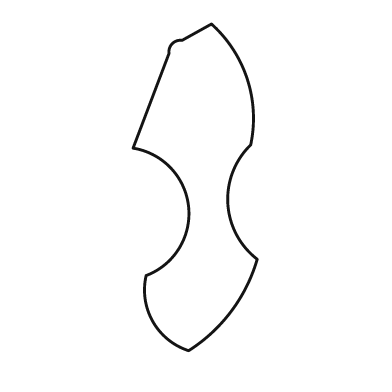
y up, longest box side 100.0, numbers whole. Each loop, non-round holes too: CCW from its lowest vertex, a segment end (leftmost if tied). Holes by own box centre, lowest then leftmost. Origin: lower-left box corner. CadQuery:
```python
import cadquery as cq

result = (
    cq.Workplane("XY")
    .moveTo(17.0, 0.0)
    .threePointArc((30.0, 12.0), (38.0, 28.0))
    .threePointArc((29.0, 45.0), (36.0, 63.0))
    .threePointArc((35.0, 83.0), (24.0, 100.0))
    .lineTo(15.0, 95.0)
    .threePointArc((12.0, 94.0), (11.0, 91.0))
    .lineTo(0.0, 62.0)
    .threePointArc((17.0, 44.0), (4.0, 23.0))
    .threePointArc((6.0, 9.0), (17.0, 0.0))
    .close()
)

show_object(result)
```